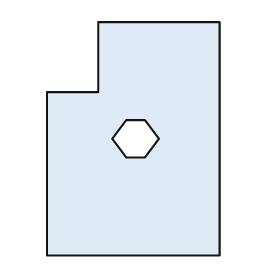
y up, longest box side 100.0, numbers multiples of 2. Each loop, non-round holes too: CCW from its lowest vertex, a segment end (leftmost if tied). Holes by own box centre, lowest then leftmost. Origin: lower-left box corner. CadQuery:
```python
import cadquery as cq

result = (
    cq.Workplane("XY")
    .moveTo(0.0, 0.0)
    .lineTo(74.0, 0.0)
    .lineTo(74.0, 100.0)
    .lineTo(22.0, 100.0)
    .lineTo(22.0, 70.0)
    .lineTo(0.0, 70.0)
    .close()
    .moveTo(34.0, 42.0)
    .lineTo(42.0, 42.0)
    .lineTo(48.0, 50.0)
    .lineTo(42.0, 58.0)
    .lineTo(34.0, 58.0)
    .lineTo(28.0, 50.0)
    .close()
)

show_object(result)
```